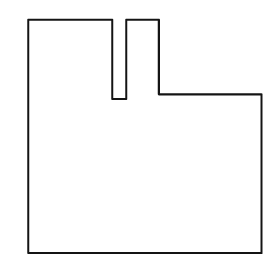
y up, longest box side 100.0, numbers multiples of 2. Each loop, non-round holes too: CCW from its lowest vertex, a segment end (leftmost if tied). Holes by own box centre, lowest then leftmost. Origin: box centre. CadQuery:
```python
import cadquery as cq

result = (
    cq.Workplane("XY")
    .moveTo(-50.0, -50.0)
    .lineTo(50.0, -50.0)
    .lineTo(50.0, 18.0)
    .lineTo(6.0, 18.0)
    .lineTo(6.0, 50.0)
    .lineTo(-8.0, 50.0)
    .lineTo(-8.0, 16.0)
    .lineTo(-14.0, 16.0)
    .lineTo(-14.0, 50.0)
    .lineTo(-50.0, 50.0)
    .close()
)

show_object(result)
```